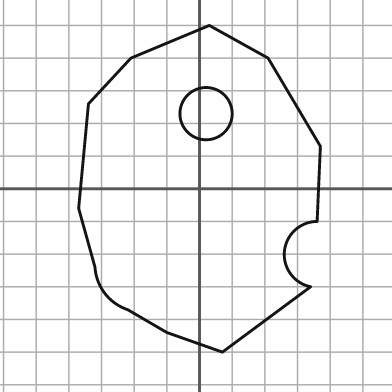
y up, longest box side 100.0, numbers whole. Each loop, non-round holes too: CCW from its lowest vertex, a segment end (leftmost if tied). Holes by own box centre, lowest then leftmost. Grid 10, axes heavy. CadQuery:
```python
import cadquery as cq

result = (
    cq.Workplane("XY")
    .moveTo(7.0, -50.0)
    .lineTo(34.0, -30.0)
    .threePointArc((26.0, -19.0), (36.0, -10.0))
    .lineTo(37.0, 13.0)
    .lineTo(21.0, 40.0)
    .lineTo(3.0, 50.0)
    .lineTo(-21.0, 40.0)
    .lineTo(-34.0, 26.0)
    .lineTo(-37.0, -6.0)
    .lineTo(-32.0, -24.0)
    .threePointArc((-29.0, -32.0), (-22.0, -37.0))
    .lineTo(-10.0, -44.0)
    .close()
    .moveTo(2.0, 23.0)
    .circle(8.0)
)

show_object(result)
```